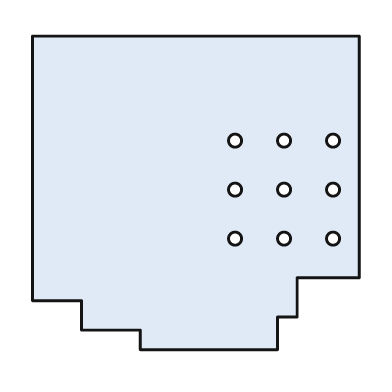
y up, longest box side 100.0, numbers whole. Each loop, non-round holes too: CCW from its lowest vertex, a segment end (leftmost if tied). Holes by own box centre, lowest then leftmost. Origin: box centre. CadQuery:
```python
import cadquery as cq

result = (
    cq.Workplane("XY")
    .moveTo(-17.0, -48.0)
    .lineTo(25.0, -48.0)
    .lineTo(25.0, -38.0)
    .lineTo(31.0, -38.0)
    .lineTo(31.0, -26.0)
    .lineTo(50.0, -26.0)
    .lineTo(50.0, 48.0)
    .lineTo(-50.0, 48.0)
    .lineTo(-50.0, -33.0)
    .lineTo(-35.0, -33.0)
    .lineTo(-35.0, -42.0)
    .lineTo(-17.0, -42.0)
    .close()
    .moveTo(12.0, -14.0)
    .circle(2.0)
    .moveTo(27.0, -14.0)
    .circle(2.0)
    .moveTo(42.0, -14.0)
    .circle(2.0)
    .moveTo(12.0, 1.0)
    .circle(2.0)
    .moveTo(27.0, 1.0)
    .circle(2.0)
    .moveTo(42.0, 1.0)
    .circle(2.0)
    .moveTo(12.0, 16.0)
    .circle(2.0)
    .moveTo(27.0, 16.0)
    .circle(2.0)
    .moveTo(42.0, 16.0)
    .circle(2.0)
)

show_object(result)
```